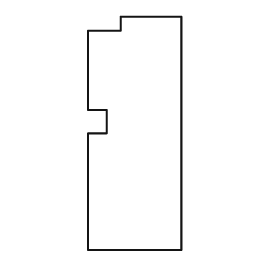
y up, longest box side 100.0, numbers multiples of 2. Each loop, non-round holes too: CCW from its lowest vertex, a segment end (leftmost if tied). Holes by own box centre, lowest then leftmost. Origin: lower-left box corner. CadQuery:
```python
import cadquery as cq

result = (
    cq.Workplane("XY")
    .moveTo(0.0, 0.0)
    .lineTo(40.0, 0.0)
    .lineTo(40.0, 100.0)
    .lineTo(14.0, 100.0)
    .lineTo(14.0, 94.0)
    .lineTo(0.0, 94.0)
    .lineTo(0.0, 60.0)
    .lineTo(8.0, 60.0)
    .lineTo(8.0, 50.0)
    .lineTo(0.0, 50.0)
    .close()
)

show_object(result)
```